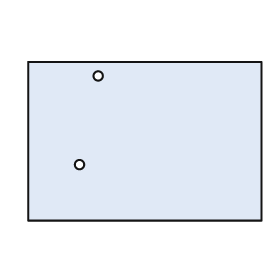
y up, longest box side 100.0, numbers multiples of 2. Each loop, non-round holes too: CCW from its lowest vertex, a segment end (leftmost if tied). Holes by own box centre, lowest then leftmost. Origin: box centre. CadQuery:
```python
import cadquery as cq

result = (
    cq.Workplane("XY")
    .moveTo(-50.0, -34.0)
    .lineTo(50.0, -34.0)
    .lineTo(50.0, 34.0)
    .lineTo(-50.0, 34.0)
    .close()
    .moveTo(-28.0, -10.0)
    .circle(2.0)
    .moveTo(-20.0, 28.0)
    .circle(2.0)
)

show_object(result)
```